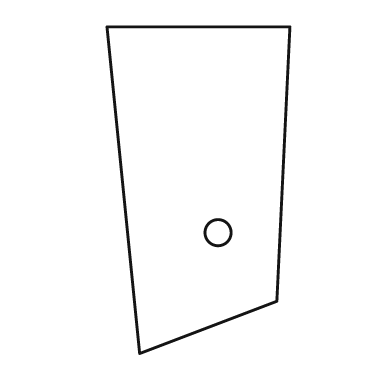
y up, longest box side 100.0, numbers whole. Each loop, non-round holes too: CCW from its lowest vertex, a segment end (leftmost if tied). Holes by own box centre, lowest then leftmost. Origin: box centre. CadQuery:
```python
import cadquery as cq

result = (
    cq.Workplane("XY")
    .moveTo(-18.0, -50.0)
    .lineTo(24.0, -34.0)
    .lineTo(28.0, 50.0)
    .lineTo(-28.0, 50.0)
    .close()
    .moveTo(6.0, -13.0)
    .circle(4.0)
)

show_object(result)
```